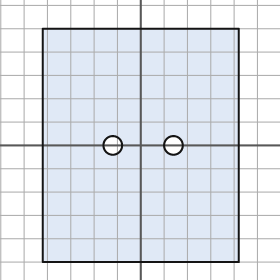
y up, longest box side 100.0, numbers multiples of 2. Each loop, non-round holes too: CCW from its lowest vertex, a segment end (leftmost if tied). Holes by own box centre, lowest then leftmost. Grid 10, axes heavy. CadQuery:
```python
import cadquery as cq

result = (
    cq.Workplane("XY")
    .moveTo(-42.0, -50.0)
    .lineTo(42.0, -50.0)
    .lineTo(42.0, 50.0)
    .lineTo(-42.0, 50.0)
    .close()
    .moveTo(-12.0, 0.0)
    .circle(4.0)
    .moveTo(14.0, 0.0)
    .circle(4.0)
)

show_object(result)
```